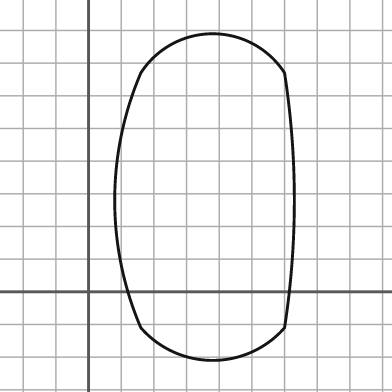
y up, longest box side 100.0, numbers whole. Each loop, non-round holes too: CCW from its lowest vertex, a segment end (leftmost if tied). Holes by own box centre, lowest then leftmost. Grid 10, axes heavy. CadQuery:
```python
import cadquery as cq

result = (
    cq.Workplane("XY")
    .moveTo(16.0, -11.0)
    .threePointArc((38.0, -21.0), (60.0, -11.0))
    .threePointArc((63.0, 28.0), (60.0, 67.0))
    .threePointArc((38.0, 79.0), (16.0, 67.0))
    .threePointArc((8.0, 28.0), (16.0, -11.0))
    .close()
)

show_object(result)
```